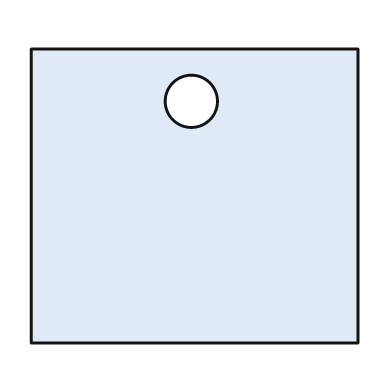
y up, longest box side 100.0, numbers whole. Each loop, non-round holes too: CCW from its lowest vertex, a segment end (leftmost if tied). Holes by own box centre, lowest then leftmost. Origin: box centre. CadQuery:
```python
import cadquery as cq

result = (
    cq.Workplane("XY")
    .moveTo(-50.0, -45.0)
    .lineTo(50.0, -45.0)
    .lineTo(50.0, 45.0)
    .lineTo(-50.0, 45.0)
    .close()
    .moveTo(-1.0, 29.0)
    .circle(8.0)
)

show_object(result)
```